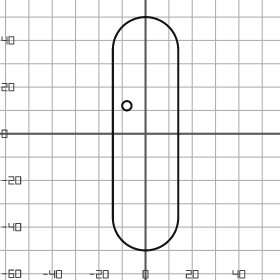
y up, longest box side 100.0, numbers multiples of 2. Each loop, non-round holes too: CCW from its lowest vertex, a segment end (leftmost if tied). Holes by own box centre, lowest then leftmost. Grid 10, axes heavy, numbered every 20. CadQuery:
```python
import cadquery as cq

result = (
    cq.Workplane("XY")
    .moveTo(-14.0, -36.0)
    .threePointArc((0.0, -50.0), (14.0, -36.0))
    .lineTo(14.0, 36.0)
    .threePointArc((0.0, 50.0), (-14.0, 36.0))
    .close()
    .moveTo(-8.0, 12.0)
    .circle(2.0)
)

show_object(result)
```